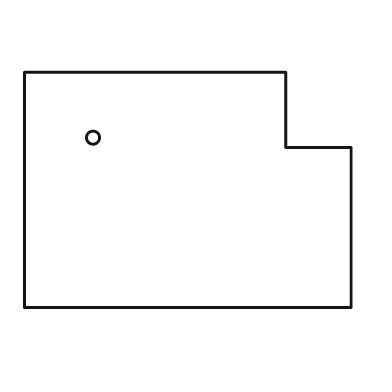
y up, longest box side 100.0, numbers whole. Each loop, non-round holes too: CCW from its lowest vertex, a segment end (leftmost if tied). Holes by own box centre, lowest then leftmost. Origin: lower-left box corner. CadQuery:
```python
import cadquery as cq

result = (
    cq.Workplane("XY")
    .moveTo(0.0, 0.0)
    .lineTo(100.0, 0.0)
    .lineTo(100.0, 49.0)
    .lineTo(80.0, 49.0)
    .lineTo(80.0, 72.0)
    .lineTo(0.0, 72.0)
    .close()
    .moveTo(21.0, 52.0)
    .circle(2.0)
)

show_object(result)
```